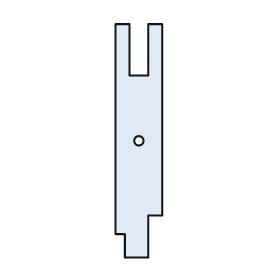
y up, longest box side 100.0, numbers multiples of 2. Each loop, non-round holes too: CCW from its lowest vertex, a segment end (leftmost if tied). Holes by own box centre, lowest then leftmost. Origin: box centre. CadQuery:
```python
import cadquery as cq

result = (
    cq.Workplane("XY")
    .moveTo(-6.0, -50.0)
    .lineTo(4.0, -50.0)
    .lineTo(4.0, -32.0)
    .lineTo(10.0, -32.0)
    .lineTo(10.0, 50.0)
    .lineTo(4.0, 50.0)
    .lineTo(4.0, 28.0)
    .lineTo(-4.0, 28.0)
    .lineTo(-4.0, 50.0)
    .lineTo(-10.0, 50.0)
    .lineTo(-10.0, -40.0)
    .lineTo(-6.0, -40.0)
    .close()
    .moveTo(0.0, 0.0)
    .circle(2.0)
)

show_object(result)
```